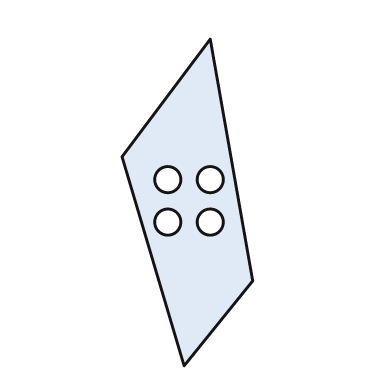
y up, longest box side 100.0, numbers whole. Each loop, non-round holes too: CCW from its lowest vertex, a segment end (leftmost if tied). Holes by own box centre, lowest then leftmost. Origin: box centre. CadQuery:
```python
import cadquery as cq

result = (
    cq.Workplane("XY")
    .moveTo(-1.0, -50.0)
    .lineTo(20.0, -24.0)
    .lineTo(7.0, 50.0)
    .lineTo(-20.0, 14.0)
    .close()
    .moveTo(-6.0, -6.0)
    .circle(4.0)
    .moveTo(7.0, -6.0)
    .circle(4.0)
    .moveTo(-6.0, 7.0)
    .circle(4.0)
    .moveTo(7.0, 7.0)
    .circle(4.0)
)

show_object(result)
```